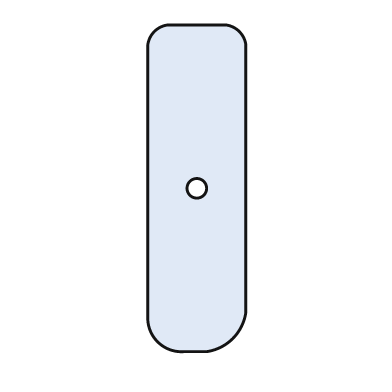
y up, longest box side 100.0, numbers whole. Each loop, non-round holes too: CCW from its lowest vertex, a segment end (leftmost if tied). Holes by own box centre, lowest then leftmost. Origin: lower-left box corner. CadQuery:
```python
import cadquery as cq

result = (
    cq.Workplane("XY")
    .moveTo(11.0, 0.0)
    .lineTo(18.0, 0.0)
    .threePointArc((26.0, 4.0), (30.0, 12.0))
    .lineTo(30.0, 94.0)
    .threePointArc((28.0, 98.0), (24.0, 100.0))
    .lineTo(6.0, 100.0)
    .threePointArc((2.0, 98.0), (0.0, 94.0))
    .lineTo(0.0, 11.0)
    .threePointArc((3.0, 3.0), (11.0, 0.0))
    .close()
    .moveTo(15.0, 50.0)
    .circle(3.0)
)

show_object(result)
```